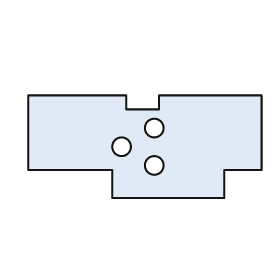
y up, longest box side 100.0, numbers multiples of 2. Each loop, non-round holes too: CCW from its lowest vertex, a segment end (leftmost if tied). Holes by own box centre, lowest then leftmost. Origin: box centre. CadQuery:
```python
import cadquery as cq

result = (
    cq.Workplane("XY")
    .moveTo(-14.0, -22.0)
    .lineTo(34.0, -22.0)
    .lineTo(34.0, -10.0)
    .lineTo(50.0, -10.0)
    .lineTo(50.0, 22.0)
    .lineTo(6.0, 22.0)
    .lineTo(6.0, 16.0)
    .lineTo(-8.0, 16.0)
    .lineTo(-8.0, 22.0)
    .lineTo(-50.0, 22.0)
    .lineTo(-50.0, -10.0)
    .lineTo(-14.0, -10.0)
    .close()
    .moveTo(4.0, -8.0)
    .circle(4.0)
    .moveTo(-10.0, 0.0)
    .circle(4.0)
    .moveTo(4.0, 8.0)
    .circle(4.0)
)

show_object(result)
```